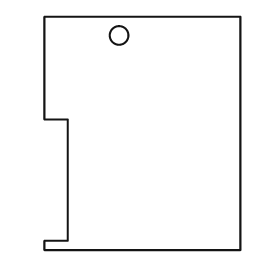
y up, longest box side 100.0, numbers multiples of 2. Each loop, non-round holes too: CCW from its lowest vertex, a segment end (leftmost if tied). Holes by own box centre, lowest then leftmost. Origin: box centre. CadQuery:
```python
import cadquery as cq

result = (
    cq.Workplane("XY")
    .moveTo(-42.0, -50.0)
    .lineTo(42.0, -50.0)
    .lineTo(42.0, 50.0)
    .lineTo(-42.0, 50.0)
    .lineTo(-42.0, 6.0)
    .lineTo(-32.0, 6.0)
    .lineTo(-32.0, -46.0)
    .lineTo(-42.0, -46.0)
    .close()
    .moveTo(-10.0, 42.0)
    .circle(4.0)
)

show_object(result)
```